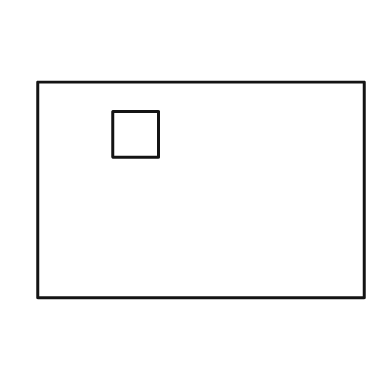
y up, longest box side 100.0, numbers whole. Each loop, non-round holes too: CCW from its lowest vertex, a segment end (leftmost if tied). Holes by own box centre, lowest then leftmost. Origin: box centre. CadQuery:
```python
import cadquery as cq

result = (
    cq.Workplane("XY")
    .moveTo(-50.0, -33.0)
    .lineTo(50.0, -33.0)
    .lineTo(50.0, 33.0)
    .lineTo(-50.0, 33.0)
    .close()
    .moveTo(-27.0, 10.0)
    .lineTo(-13.0, 10.0)
    .lineTo(-13.0, 24.0)
    .lineTo(-27.0, 24.0)
    .close()
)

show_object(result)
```